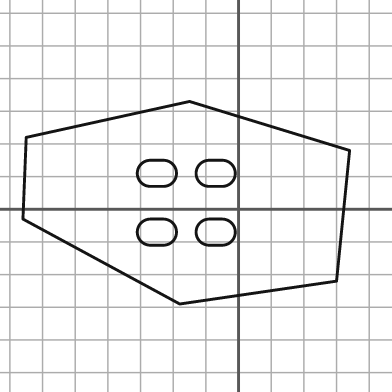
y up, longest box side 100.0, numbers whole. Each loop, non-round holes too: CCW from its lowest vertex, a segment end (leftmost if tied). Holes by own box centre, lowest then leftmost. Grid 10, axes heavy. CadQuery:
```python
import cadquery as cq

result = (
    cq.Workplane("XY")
    .moveTo(-18.0, -29.0)
    .lineTo(30.0, -22.0)
    .lineTo(34.0, 18.0)
    .lineTo(-15.0, 33.0)
    .lineTo(-65.0, 22.0)
    .lineTo(-66.0, -3.0)
    .close()
    .moveTo(-27.0, -11.0)
    .lineTo(-23.0, -11.0)
    .threePointArc((-19.0, -7.0), (-23.0, -3.0))
    .lineTo(-27.0, -3.0)
    .threePointArc((-31.0, -7.0), (-27.0, -11.0))
    .close()
    .moveTo(-9.0, -11.0)
    .lineTo(-5.0, -11.0)
    .threePointArc((-1.0, -7.0), (-5.0, -3.0))
    .lineTo(-9.0, -3.0)
    .threePointArc((-13.0, -7.0), (-9.0, -11.0))
    .close()
    .moveTo(-27.0, 7.0)
    .lineTo(-23.0, 7.0)
    .threePointArc((-19.0, 11.0), (-23.0, 15.0))
    .lineTo(-27.0, 15.0)
    .threePointArc((-31.0, 11.0), (-27.0, 7.0))
    .close()
    .moveTo(-9.0, 7.0)
    .lineTo(-5.0, 7.0)
    .threePointArc((-1.0, 11.0), (-5.0, 15.0))
    .lineTo(-9.0, 15.0)
    .threePointArc((-13.0, 11.0), (-9.0, 7.0))
    .close()
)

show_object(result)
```